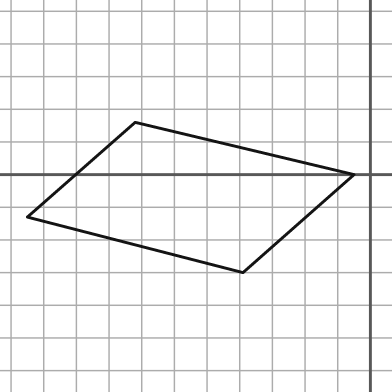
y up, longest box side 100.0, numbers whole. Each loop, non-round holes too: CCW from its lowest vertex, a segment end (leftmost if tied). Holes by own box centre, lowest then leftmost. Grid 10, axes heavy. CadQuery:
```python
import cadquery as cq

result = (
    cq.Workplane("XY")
    .moveTo(-39.0, -30.0)
    .lineTo(-5.0, 0.0)
    .lineTo(-72.0, 16.0)
    .lineTo(-105.0, -13.0)
    .close()
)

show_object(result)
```